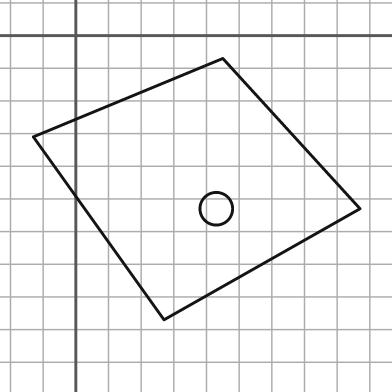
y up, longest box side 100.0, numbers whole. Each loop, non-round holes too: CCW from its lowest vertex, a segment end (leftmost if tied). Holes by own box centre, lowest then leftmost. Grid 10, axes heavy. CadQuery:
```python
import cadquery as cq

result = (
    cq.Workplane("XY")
    .moveTo(27.0, -87.0)
    .lineTo(87.0, -53.0)
    .lineTo(45.0, -7.0)
    .lineTo(-13.0, -31.0)
    .close()
    .moveTo(43.0, -53.0)
    .circle(5.0)
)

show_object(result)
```